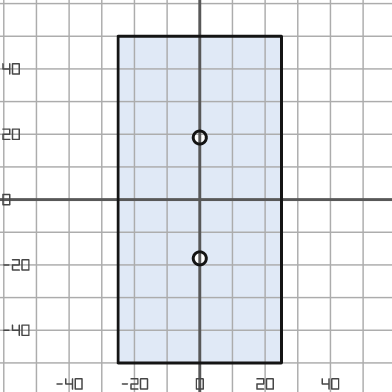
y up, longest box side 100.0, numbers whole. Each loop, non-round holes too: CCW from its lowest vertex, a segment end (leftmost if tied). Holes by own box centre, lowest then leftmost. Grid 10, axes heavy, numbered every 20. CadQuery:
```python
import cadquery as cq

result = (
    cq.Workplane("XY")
    .moveTo(-25.0, -50.0)
    .lineTo(25.0, -50.0)
    .lineTo(25.0, 50.0)
    .lineTo(-25.0, 50.0)
    .close()
    .moveTo(0.0, -18.0)
    .circle(2.0)
    .moveTo(0.0, 19.0)
    .circle(2.0)
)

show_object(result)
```